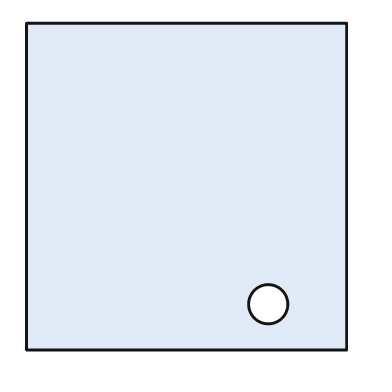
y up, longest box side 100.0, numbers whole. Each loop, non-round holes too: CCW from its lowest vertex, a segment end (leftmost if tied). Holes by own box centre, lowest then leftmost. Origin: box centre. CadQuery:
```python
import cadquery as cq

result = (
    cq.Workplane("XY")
    .moveTo(-49.0, -50.0)
    .lineTo(49.0, -50.0)
    .lineTo(49.0, 50.0)
    .lineTo(-49.0, 50.0)
    .close()
    .moveTo(25.0, -36.0)
    .circle(6.0)
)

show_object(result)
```